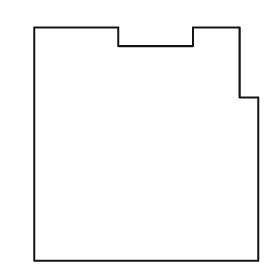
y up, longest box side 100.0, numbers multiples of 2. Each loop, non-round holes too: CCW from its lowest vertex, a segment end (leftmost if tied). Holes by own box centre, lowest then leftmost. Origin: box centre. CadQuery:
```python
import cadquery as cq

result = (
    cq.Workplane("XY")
    .moveTo(-48.0, -50.0)
    .lineTo(48.0, -50.0)
    .lineTo(48.0, 20.0)
    .lineTo(40.0, 20.0)
    .lineTo(40.0, 50.0)
    .lineTo(20.0, 50.0)
    .lineTo(20.0, 42.0)
    .lineTo(-12.0, 42.0)
    .lineTo(-12.0, 50.0)
    .lineTo(-48.0, 50.0)
    .close()
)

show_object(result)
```